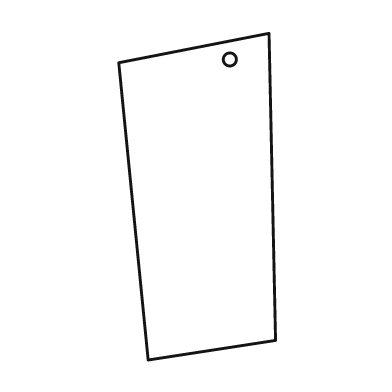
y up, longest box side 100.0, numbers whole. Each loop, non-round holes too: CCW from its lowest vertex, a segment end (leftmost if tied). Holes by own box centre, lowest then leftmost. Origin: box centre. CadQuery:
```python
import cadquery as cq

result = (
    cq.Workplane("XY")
    .moveTo(-15.0, -50.0)
    .lineTo(24.0, -44.0)
    .lineTo(22.0, 50.0)
    .lineTo(-24.0, 41.0)
    .close()
    .moveTo(10.0, 42.0)
    .circle(2.0)
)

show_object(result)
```